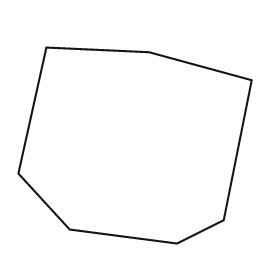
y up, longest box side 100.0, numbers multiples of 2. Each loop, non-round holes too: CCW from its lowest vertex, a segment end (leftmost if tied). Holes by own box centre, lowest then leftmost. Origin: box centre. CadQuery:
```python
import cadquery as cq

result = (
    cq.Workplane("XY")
    .moveTo(18.0, -42.0)
    .lineTo(38.0, -32.0)
    .lineTo(50.0, 28.0)
    .lineTo(6.0, 40.0)
    .lineTo(-38.0, 42.0)
    .lineTo(-50.0, -12.0)
    .lineTo(-28.0, -36.0)
    .close()
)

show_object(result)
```